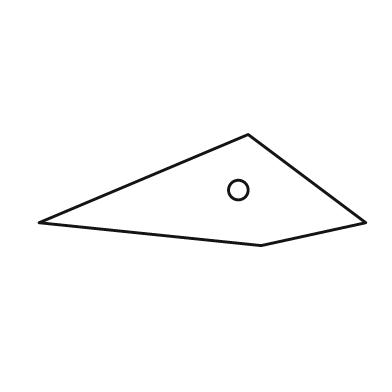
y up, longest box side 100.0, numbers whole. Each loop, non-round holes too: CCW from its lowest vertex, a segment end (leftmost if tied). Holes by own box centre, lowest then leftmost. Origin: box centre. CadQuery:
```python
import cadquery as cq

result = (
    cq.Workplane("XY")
    .moveTo(18.0, -17.0)
    .lineTo(50.0, -10.0)
    .lineTo(14.0, 17.0)
    .lineTo(-50.0, -10.0)
    .close()
    .moveTo(11.0, 0.0)
    .circle(3.0)
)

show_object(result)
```